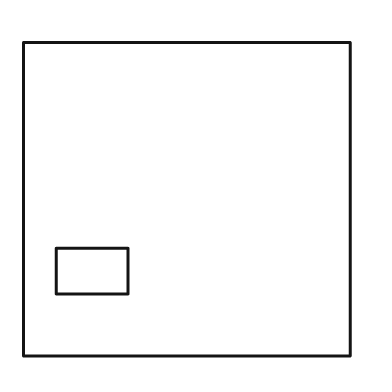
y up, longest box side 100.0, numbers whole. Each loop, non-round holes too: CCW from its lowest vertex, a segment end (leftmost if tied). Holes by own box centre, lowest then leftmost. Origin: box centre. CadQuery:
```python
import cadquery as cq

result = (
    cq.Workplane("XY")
    .moveTo(-50.0, -48.0)
    .lineTo(50.0, -48.0)
    .lineTo(50.0, 48.0)
    .lineTo(-50.0, 48.0)
    .close()
    .moveTo(-40.0, -29.0)
    .lineTo(-18.0, -29.0)
    .lineTo(-18.0, -15.0)
    .lineTo(-40.0, -15.0)
    .close()
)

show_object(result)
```